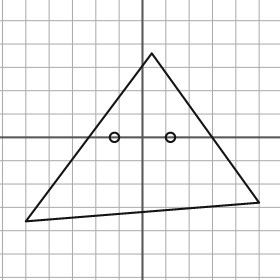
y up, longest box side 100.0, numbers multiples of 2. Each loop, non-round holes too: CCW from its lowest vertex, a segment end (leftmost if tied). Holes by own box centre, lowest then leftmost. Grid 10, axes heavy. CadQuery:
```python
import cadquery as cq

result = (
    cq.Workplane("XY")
    .moveTo(-50.0, -36.0)
    .lineTo(50.0, -28.0)
    .lineTo(4.0, 36.0)
    .close()
    .moveTo(-12.0, 0.0)
    .circle(2.0)
    .moveTo(12.0, 0.0)
    .circle(2.0)
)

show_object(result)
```